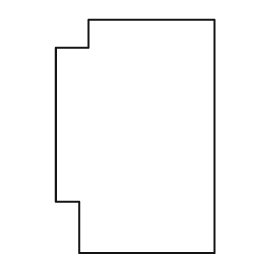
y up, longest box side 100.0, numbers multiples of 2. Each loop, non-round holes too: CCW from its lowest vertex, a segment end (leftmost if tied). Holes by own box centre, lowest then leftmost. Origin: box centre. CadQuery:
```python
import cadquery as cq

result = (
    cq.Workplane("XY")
    .moveTo(-24.0, -50.0)
    .lineTo(34.0, -50.0)
    .lineTo(34.0, 50.0)
    .lineTo(-20.0, 50.0)
    .lineTo(-20.0, 38.0)
    .lineTo(-34.0, 38.0)
    .lineTo(-34.0, -28.0)
    .lineTo(-24.0, -28.0)
    .close()
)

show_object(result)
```